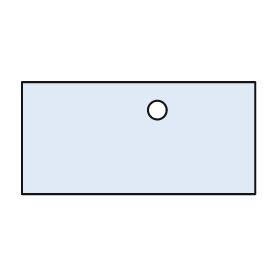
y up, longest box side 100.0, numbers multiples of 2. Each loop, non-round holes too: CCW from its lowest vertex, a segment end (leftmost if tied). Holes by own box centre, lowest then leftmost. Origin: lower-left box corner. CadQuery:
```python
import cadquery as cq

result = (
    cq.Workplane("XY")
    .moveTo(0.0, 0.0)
    .lineTo(100.0, 0.0)
    .lineTo(100.0, 48.0)
    .lineTo(0.0, 48.0)
    .close()
    .moveTo(58.0, 36.0)
    .circle(4.0)
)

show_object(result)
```